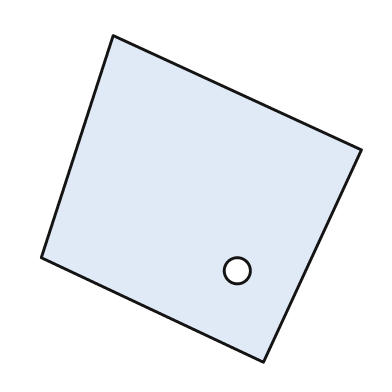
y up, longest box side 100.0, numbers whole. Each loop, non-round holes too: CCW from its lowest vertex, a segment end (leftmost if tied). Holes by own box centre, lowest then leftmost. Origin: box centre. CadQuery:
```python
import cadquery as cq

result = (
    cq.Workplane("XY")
    .moveTo(19.0, -50.0)
    .lineTo(49.0, 15.0)
    .lineTo(-27.0, 50.0)
    .lineTo(-49.0, -18.0)
    .close()
    .moveTo(11.0, -22.0)
    .circle(4.0)
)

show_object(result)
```